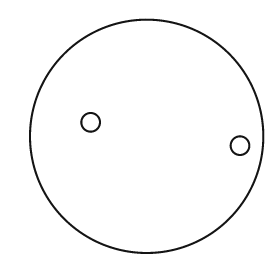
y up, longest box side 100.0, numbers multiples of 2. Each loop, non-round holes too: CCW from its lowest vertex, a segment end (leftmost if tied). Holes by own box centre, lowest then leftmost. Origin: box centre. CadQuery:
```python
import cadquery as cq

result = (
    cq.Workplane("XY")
    .moveTo(0.0, 0.0)
    .circle(50.0)
    .moveTo(40.0, -4.0)
    .circle(4.0)
    .moveTo(-24.0, 6.0)
    .circle(4.0)
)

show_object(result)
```